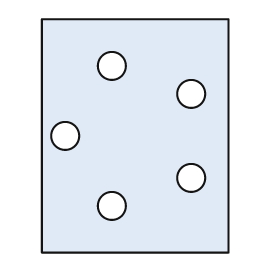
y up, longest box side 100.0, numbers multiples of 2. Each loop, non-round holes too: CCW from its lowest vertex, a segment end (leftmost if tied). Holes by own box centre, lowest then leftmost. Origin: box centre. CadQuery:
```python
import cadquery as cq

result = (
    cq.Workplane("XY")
    .moveTo(-40.0, -50.0)
    .lineTo(40.0, -50.0)
    .lineTo(40.0, 50.0)
    .lineTo(-40.0, 50.0)
    .close()
    .moveTo(-10.0, -30.0)
    .circle(6.0)
    .moveTo(24.0, -18.0)
    .circle(6.0)
    .moveTo(-30.0, 0.0)
    .circle(6.0)
    .moveTo(24.0, 18.0)
    .circle(6.0)
    .moveTo(-10.0, 30.0)
    .circle(6.0)
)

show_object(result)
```